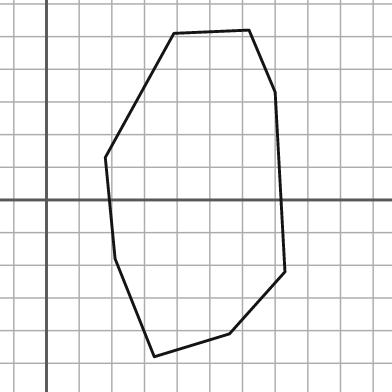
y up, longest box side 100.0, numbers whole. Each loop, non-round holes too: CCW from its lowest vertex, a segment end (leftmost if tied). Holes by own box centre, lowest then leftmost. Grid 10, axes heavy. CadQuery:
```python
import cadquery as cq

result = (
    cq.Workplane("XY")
    .moveTo(33.0, -48.0)
    .lineTo(56.0, -41.0)
    .lineTo(73.0, -22.0)
    .lineTo(70.0, 33.0)
    .lineTo(62.0, 52.0)
    .lineTo(39.0, 51.0)
    .lineTo(18.0, 13.0)
    .lineTo(21.0, -18.0)
    .close()
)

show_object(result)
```